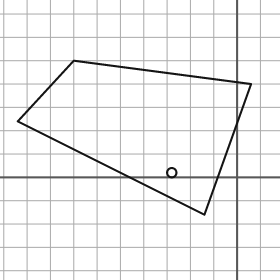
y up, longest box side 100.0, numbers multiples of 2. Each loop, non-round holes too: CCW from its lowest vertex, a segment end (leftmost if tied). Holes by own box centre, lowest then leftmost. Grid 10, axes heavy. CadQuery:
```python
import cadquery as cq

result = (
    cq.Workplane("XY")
    .moveTo(-14.0, -16.0)
    .lineTo(6.0, 40.0)
    .lineTo(-70.0, 50.0)
    .lineTo(-94.0, 24.0)
    .close()
    .moveTo(-28.0, 2.0)
    .circle(2.0)
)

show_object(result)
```